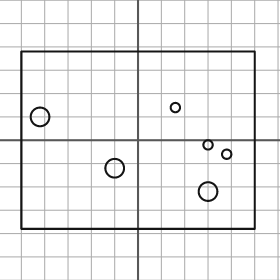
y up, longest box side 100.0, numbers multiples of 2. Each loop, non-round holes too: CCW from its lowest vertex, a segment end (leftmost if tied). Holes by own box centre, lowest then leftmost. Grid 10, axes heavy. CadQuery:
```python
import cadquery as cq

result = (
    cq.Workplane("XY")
    .moveTo(-50.0, -38.0)
    .lineTo(50.0, -38.0)
    .lineTo(50.0, 38.0)
    .lineTo(-50.0, 38.0)
    .close()
    .moveTo(30.0, -22.0)
    .circle(4.0)
    .moveTo(-10.0, -12.0)
    .circle(4.0)
    .moveTo(38.0, -6.0)
    .circle(2.0)
    .moveTo(30.0, -2.0)
    .circle(2.0)
    .moveTo(-42.0, 10.0)
    .circle(4.0)
    .moveTo(16.0, 14.0)
    .circle(2.0)
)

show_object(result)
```